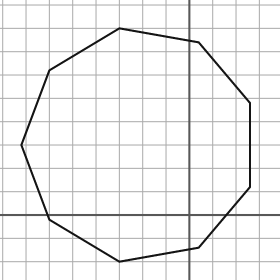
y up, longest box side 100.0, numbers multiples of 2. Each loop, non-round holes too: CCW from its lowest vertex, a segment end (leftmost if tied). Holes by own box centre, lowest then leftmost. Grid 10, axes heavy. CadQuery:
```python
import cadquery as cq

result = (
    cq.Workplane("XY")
    .moveTo(-30.0, -20.0)
    .lineTo(4.0, -14.0)
    .lineTo(26.0, 12.0)
    .lineTo(26.0, 48.0)
    .lineTo(4.0, 74.0)
    .lineTo(-30.0, 80.0)
    .lineTo(-60.0, 62.0)
    .lineTo(-72.0, 30.0)
    .lineTo(-60.0, -2.0)
    .close()
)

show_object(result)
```